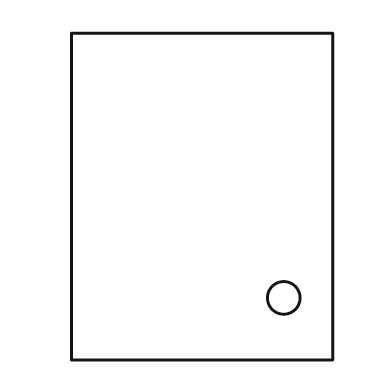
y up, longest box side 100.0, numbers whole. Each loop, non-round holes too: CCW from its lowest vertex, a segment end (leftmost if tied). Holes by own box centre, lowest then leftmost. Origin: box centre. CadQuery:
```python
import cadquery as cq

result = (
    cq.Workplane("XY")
    .moveTo(-40.0, -50.0)
    .lineTo(40.0, -50.0)
    .lineTo(40.0, 50.0)
    .lineTo(-40.0, 50.0)
    .close()
    .moveTo(25.0, -31.0)
    .circle(5.0)
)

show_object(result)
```